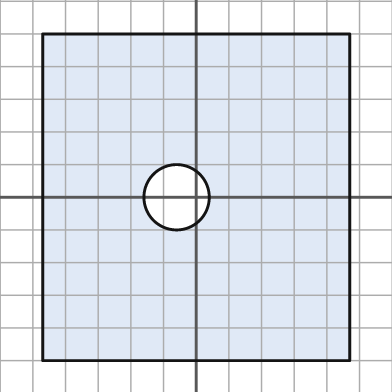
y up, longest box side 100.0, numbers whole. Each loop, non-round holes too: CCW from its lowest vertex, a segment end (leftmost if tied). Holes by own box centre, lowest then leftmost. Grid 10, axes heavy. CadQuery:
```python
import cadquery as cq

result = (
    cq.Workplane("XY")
    .moveTo(-47.0, -50.0)
    .lineTo(47.0, -50.0)
    .lineTo(47.0, 50.0)
    .lineTo(-47.0, 50.0)
    .close()
    .moveTo(-6.0, 0.0)
    .circle(10.0)
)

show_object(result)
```